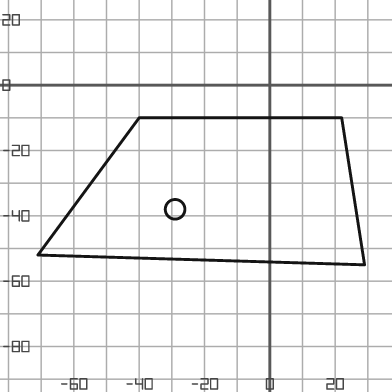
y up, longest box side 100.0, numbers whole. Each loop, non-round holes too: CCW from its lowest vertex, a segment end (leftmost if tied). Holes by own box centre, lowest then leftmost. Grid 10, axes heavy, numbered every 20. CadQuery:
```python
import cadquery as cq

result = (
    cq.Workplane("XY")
    .moveTo(29.0, -55.0)
    .lineTo(22.0, -10.0)
    .lineTo(-40.0, -10.0)
    .lineTo(-71.0, -52.0)
    .close()
    .moveTo(-29.0, -38.0)
    .circle(3.0)
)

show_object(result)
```